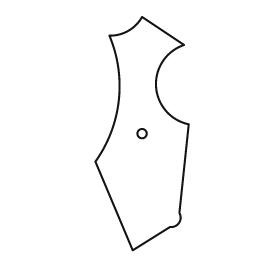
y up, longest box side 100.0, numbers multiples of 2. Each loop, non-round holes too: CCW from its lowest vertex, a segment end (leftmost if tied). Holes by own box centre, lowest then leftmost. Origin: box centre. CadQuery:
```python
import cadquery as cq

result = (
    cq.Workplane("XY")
    .moveTo(-4.0, -50.0)
    .lineTo(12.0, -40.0)
    .threePointArc((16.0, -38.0), (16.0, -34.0))
    .lineTo(20.0, 4.0)
    .threePointArc((6.0, 20.0), (18.0, 38.0))
    .lineTo(0.0, 50.0)
    .threePointArc((-6.0, 44.0), (-14.0, 42.0))
    .threePointArc((-10.0, 14.0), (-20.0, -12.0))
    .close()
    .moveTo(0.0, 0.0)
    .circle(2.0)
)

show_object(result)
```